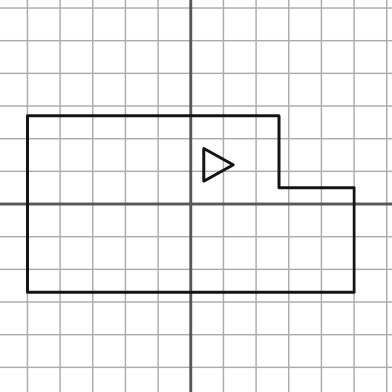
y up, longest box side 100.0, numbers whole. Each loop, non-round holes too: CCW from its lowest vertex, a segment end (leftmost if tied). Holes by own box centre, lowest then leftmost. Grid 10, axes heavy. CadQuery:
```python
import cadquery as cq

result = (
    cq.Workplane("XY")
    .moveTo(-50.0, -27.0)
    .lineTo(50.0, -27.0)
    .lineTo(50.0, 5.0)
    .lineTo(27.0, 5.0)
    .lineTo(27.0, 27.0)
    .lineTo(-50.0, 27.0)
    .close()
    .moveTo(4.0, 7.0)
    .lineTo(13.0, 12.0)
    .lineTo(4.0, 17.0)
    .close()
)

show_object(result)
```